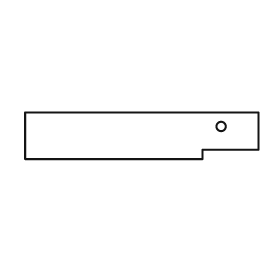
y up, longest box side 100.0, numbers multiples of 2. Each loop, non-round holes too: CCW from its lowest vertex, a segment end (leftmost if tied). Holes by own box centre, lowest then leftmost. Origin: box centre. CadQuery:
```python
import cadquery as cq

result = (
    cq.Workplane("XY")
    .moveTo(-50.0, -10.0)
    .lineTo(26.0, -10.0)
    .lineTo(26.0, -6.0)
    .lineTo(50.0, -6.0)
    .lineTo(50.0, 10.0)
    .lineTo(-50.0, 10.0)
    .close()
    .moveTo(34.0, 4.0)
    .circle(2.0)
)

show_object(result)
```